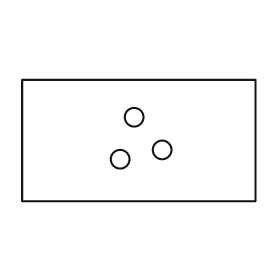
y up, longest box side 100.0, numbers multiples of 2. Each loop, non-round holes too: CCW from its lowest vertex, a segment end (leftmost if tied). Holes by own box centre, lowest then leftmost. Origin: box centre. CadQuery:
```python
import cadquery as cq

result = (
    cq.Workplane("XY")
    .moveTo(-50.0, -26.0)
    .lineTo(50.0, -26.0)
    .lineTo(50.0, 26.0)
    .lineTo(-50.0, 26.0)
    .close()
    .moveTo(-8.0, -8.0)
    .circle(4.0)
    .moveTo(10.0, -4.0)
    .circle(4.0)
    .moveTo(-2.0, 10.0)
    .circle(4.0)
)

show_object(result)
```